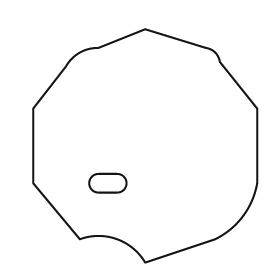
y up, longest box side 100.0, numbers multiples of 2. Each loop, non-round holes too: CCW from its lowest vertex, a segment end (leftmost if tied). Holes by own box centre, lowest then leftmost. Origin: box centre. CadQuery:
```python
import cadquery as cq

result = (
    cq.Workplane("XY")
    .moveTo(0.0, -50.0)
    .lineTo(30.0, -40.0)
    .threePointArc((42.0, -30.0), (48.0, -16.0))
    .lineTo(48.0, 16.0)
    .lineTo(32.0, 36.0)
    .threePointArc((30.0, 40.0), (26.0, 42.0))
    .lineTo(0.0, 50.0)
    .lineTo(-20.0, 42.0)
    .threePointArc((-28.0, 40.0), (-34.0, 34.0))
    .lineTo(-48.0, 16.0)
    .lineTo(-48.0, -16.0)
    .lineTo(-28.0, -40.0)
    .threePointArc((-12.0, -40.0), (0.0, -50.0))
    .close()
    .moveTo(-20.0, -20.0)
    .lineTo(-12.0, -20.0)
    .threePointArc((-8.0, -16.0), (-12.0, -12.0))
    .lineTo(-20.0, -12.0)
    .threePointArc((-24.0, -16.0), (-20.0, -20.0))
    .close()
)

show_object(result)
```